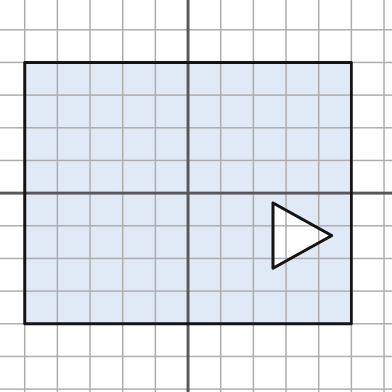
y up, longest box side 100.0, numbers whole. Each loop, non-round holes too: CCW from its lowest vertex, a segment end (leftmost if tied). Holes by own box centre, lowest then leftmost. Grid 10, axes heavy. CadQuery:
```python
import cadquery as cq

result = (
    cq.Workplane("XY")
    .moveTo(-50.0, -40.0)
    .lineTo(50.0, -40.0)
    .lineTo(50.0, 40.0)
    .lineTo(-50.0, 40.0)
    .close()
    .moveTo(26.0, -23.0)
    .lineTo(44.0, -13.0)
    .lineTo(26.0, -3.0)
    .close()
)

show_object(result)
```